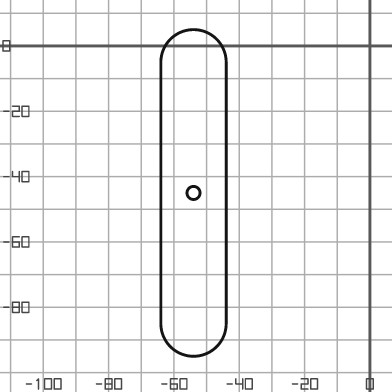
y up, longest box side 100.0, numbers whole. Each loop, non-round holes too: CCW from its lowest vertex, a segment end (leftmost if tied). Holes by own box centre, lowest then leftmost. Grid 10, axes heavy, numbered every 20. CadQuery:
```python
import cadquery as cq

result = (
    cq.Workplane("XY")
    .moveTo(-64.0, -85.0)
    .threePointArc((-54.0, -95.0), (-44.0, -85.0))
    .lineTo(-44.0, -5.0)
    .threePointArc((-54.0, 5.0), (-64.0, -5.0))
    .close()
    .moveTo(-54.0, -45.0)
    .circle(2.0)
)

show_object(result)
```